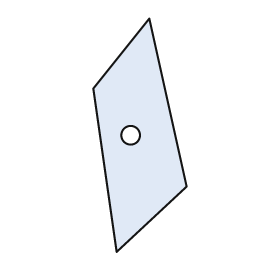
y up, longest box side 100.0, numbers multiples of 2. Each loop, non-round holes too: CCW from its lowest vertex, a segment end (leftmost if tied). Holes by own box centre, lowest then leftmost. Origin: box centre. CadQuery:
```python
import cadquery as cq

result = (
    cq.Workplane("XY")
    .moveTo(-10.0, -50.0)
    .lineTo(20.0, -22.0)
    .lineTo(4.0, 50.0)
    .lineTo(-20.0, 20.0)
    .close()
    .moveTo(-4.0, 0.0)
    .circle(4.0)
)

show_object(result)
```